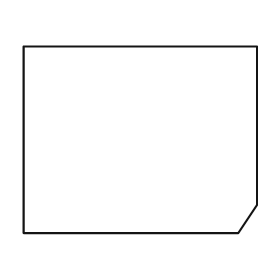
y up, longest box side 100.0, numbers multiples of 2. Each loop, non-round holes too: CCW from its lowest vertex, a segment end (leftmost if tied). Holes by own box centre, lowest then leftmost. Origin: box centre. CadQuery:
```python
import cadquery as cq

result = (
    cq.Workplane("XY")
    .moveTo(-50.0, -40.0)
    .lineTo(42.0, -40.0)
    .lineTo(50.0, -28.0)
    .lineTo(50.0, 40.0)
    .lineTo(-50.0, 40.0)
    .close()
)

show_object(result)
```